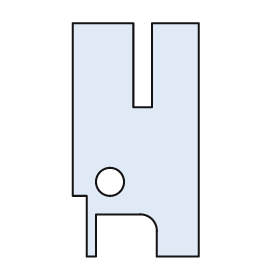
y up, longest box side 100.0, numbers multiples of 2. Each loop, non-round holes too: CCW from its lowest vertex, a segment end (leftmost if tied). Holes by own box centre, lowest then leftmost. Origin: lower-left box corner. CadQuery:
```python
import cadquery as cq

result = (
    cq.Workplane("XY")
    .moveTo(6.0, 0.0)
    .lineTo(10.0, 0.0)
    .lineTo(10.0, 18.0)
    .lineTo(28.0, 18.0)
    .threePointArc((34.0, 16.0), (36.0, 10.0))
    .lineTo(36.0, 0.0)
    .lineTo(54.0, 0.0)
    .lineTo(54.0, 100.0)
    .lineTo(34.0, 100.0)
    .lineTo(34.0, 64.0)
    .lineTo(26.0, 64.0)
    .lineTo(26.0, 100.0)
    .lineTo(0.0, 100.0)
    .lineTo(0.0, 26.0)
    .lineTo(6.0, 26.0)
    .close()
    .moveTo(16.0, 32.0)
    .circle(6.0)
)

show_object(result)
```